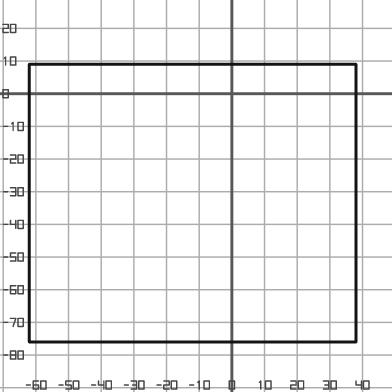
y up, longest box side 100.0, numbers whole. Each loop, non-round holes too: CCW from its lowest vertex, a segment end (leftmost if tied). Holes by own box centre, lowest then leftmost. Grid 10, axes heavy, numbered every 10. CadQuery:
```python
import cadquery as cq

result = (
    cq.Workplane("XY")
    .moveTo(-62.0, -76.0)
    .lineTo(38.0, -76.0)
    .lineTo(38.0, 9.0)
    .lineTo(-62.0, 9.0)
    .close()
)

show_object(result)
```